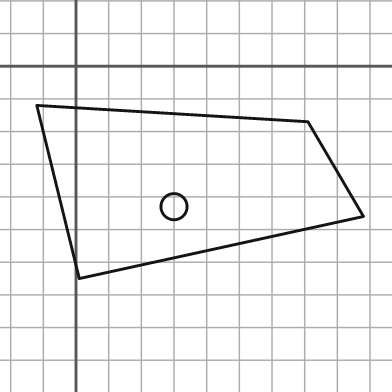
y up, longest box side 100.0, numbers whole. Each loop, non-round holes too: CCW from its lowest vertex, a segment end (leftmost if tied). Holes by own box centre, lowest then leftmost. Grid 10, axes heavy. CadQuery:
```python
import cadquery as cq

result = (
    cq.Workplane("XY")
    .moveTo(1.0, -65.0)
    .lineTo(88.0, -46.0)
    .lineTo(71.0, -17.0)
    .lineTo(-12.0, -12.0)
    .close()
    .moveTo(30.0, -43.0)
    .circle(4.0)
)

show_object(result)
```